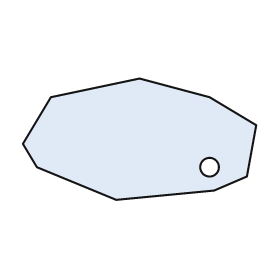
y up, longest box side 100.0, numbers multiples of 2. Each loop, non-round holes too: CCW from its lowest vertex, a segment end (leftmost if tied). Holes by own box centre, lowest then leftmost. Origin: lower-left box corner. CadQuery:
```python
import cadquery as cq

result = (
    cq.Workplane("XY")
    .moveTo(40.0, 0.0)
    .lineTo(82.0, 4.0)
    .lineTo(96.0, 10.0)
    .lineTo(100.0, 32.0)
    .lineTo(80.0, 44.0)
    .lineTo(50.0, 52.0)
    .lineTo(12.0, 44.0)
    .lineTo(0.0, 24.0)
    .lineTo(6.0, 14.0)
    .close()
    .moveTo(80.0, 14.0)
    .circle(4.0)
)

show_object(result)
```